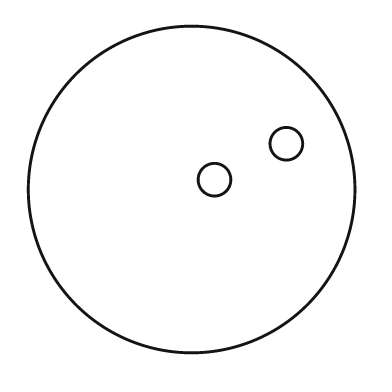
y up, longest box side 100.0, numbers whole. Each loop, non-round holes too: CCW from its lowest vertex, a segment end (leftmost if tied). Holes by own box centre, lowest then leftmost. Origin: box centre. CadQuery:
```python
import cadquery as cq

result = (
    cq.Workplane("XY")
    .moveTo(0.0, 0.0)
    .circle(50.0)
    .moveTo(7.0, 3.0)
    .circle(5.0)
    .moveTo(29.0, 14.0)
    .circle(5.0)
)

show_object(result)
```